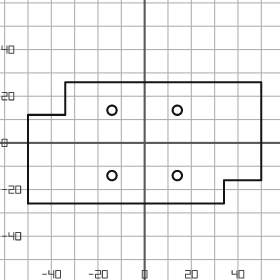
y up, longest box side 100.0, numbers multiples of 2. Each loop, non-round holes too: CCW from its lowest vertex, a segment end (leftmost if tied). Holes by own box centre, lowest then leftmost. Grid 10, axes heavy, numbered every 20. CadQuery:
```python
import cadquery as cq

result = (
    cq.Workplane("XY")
    .moveTo(-50.0, -26.0)
    .lineTo(34.0, -26.0)
    .lineTo(34.0, -16.0)
    .lineTo(50.0, -16.0)
    .lineTo(50.0, 26.0)
    .lineTo(-34.0, 26.0)
    .lineTo(-34.0, 12.0)
    .lineTo(-50.0, 12.0)
    .close()
    .moveTo(-14.0, -14.0)
    .circle(2.0)
    .moveTo(14.0, -14.0)
    .circle(2.0)
    .moveTo(-14.0, 14.0)
    .circle(2.0)
    .moveTo(14.0, 14.0)
    .circle(2.0)
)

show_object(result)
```